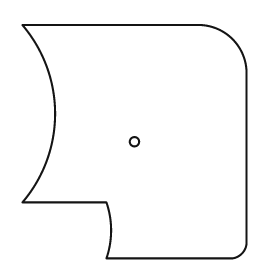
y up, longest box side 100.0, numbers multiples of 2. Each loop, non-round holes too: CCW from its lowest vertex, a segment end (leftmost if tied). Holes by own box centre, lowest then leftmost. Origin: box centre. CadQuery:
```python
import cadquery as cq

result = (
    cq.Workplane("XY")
    .moveTo(-12.0, -50.0)
    .lineTo(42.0, -50.0)
    .threePointArc((46.0, -48.0), (48.0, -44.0))
    .lineTo(48.0, 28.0)
    .threePointArc((42.0, 44.0), (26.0, 50.0))
    .lineTo(-48.0, 50.0)
    .threePointArc((-34.0, 12.0), (-48.0, -26.0))
    .lineTo(-12.0, -26.0)
    .threePointArc((-10.0, -38.0), (-12.0, -50.0))
    .close()
    .moveTo(0.0, 0.0)
    .circle(2.0)
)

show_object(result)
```